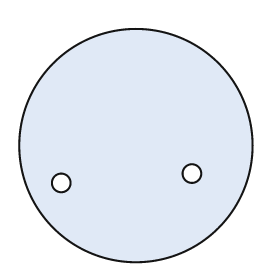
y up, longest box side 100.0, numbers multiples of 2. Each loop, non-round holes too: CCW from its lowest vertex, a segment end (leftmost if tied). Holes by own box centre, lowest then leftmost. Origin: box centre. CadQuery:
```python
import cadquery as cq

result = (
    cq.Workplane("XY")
    .moveTo(0.0, 0.0)
    .circle(50.0)
    .moveTo(-32.0, -16.0)
    .circle(4.0)
    .moveTo(24.0, -12.0)
    .circle(4.0)
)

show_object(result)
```